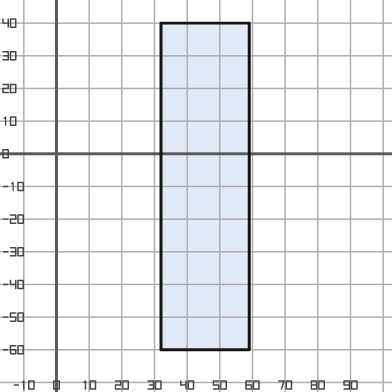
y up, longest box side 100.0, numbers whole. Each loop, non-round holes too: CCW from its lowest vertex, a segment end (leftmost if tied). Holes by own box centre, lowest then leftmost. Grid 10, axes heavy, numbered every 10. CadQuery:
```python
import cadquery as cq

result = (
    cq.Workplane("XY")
    .moveTo(32.0, -60.0)
    .lineTo(59.0, -60.0)
    .lineTo(59.0, 40.0)
    .lineTo(32.0, 40.0)
    .close()
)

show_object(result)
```